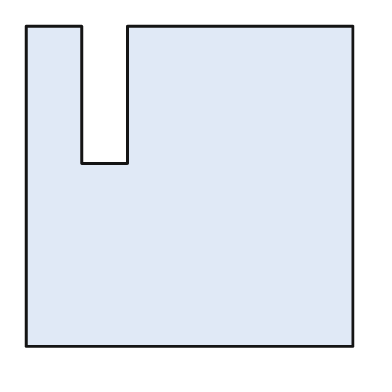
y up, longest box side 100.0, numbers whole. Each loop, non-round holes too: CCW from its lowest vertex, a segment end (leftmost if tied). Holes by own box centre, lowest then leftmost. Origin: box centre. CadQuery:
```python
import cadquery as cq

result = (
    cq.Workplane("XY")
    .moveTo(-50.0, -49.0)
    .lineTo(50.0, -49.0)
    .lineTo(50.0, 49.0)
    .lineTo(-19.0, 49.0)
    .lineTo(-19.0, 7.0)
    .lineTo(-33.0, 7.0)
    .lineTo(-33.0, 49.0)
    .lineTo(-50.0, 49.0)
    .close()
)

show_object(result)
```